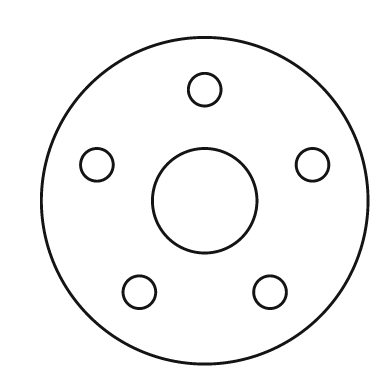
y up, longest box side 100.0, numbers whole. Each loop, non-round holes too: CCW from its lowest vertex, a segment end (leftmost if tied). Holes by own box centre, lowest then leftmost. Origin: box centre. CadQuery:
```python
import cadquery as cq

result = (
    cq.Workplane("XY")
    .moveTo(0.0, 0.0)
    .circle(50.0)
    .moveTo(-20.0, -28.0)
    .circle(5.0)
    .moveTo(20.0, -28.0)
    .circle(5.0)
    .moveTo(0.0, 0.0)
    .circle(16.0)
    .moveTo(-33.0, 11.0)
    .circle(5.0)
    .moveTo(33.0, 11.0)
    .circle(5.0)
    .moveTo(0.0, 34.0)
    .circle(5.0)
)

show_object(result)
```